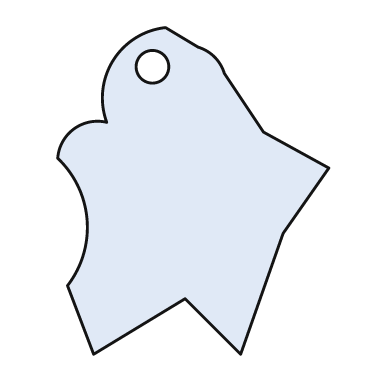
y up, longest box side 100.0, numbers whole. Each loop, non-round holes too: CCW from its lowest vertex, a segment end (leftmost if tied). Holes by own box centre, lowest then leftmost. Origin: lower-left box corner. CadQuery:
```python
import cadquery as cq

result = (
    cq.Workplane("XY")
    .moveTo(11.0, 0.0)
    .lineTo(39.0, 17.0)
    .lineTo(56.0, 0.0)
    .lineTo(69.0, 37.0)
    .lineTo(83.0, 57.0)
    .lineTo(63.0, 68.0)
    .lineTo(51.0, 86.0)
    .threePointArc((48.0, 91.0), (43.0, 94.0))
    .lineTo(33.0, 100.0)
    .threePointArc((17.0, 90.0), (15.0, 71.0))
    .threePointArc((5.0, 69.0), (0.0, 60.0))
    .threePointArc((9.0, 41.0), (3.0, 21.0))
    .close()
    .moveTo(29.0, 88.0)
    .circle(5.0)
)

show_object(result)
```